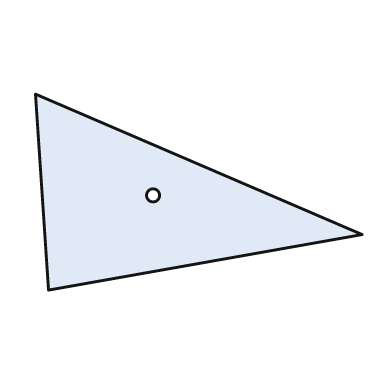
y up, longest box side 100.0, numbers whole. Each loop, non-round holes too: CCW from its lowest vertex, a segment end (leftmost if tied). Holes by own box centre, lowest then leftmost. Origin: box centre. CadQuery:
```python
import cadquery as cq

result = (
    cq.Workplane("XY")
    .moveTo(-46.0, -30.0)
    .lineTo(50.0, -13.0)
    .lineTo(-50.0, 30.0)
    .close()
    .moveTo(-14.0, -1.0)
    .circle(2.0)
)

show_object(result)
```